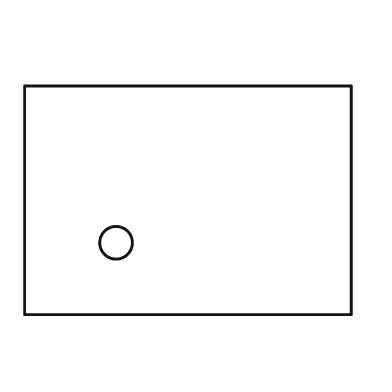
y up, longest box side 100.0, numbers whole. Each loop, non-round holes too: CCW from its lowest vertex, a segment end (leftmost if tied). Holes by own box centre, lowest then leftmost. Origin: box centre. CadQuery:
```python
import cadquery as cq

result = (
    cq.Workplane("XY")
    .moveTo(-50.0, -35.0)
    .lineTo(50.0, -35.0)
    .lineTo(50.0, 35.0)
    .lineTo(-50.0, 35.0)
    .close()
    .moveTo(-22.0, -13.0)
    .circle(5.0)
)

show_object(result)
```